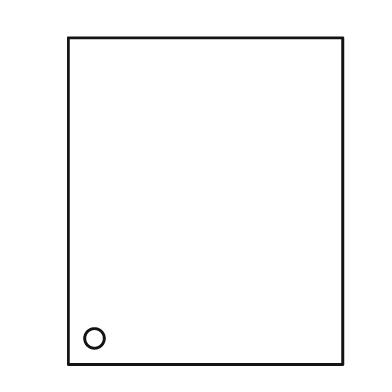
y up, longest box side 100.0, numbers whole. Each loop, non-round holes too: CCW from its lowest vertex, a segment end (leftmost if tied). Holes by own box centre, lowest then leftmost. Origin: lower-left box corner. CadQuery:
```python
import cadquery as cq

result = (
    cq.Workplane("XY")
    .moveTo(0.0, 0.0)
    .lineTo(84.0, 0.0)
    .lineTo(84.0, 100.0)
    .lineTo(0.0, 100.0)
    .close()
    .moveTo(8.0, 8.0)
    .circle(3.0)
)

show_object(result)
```